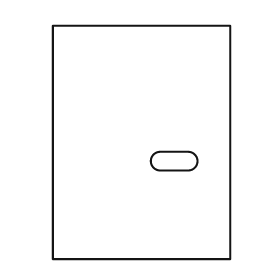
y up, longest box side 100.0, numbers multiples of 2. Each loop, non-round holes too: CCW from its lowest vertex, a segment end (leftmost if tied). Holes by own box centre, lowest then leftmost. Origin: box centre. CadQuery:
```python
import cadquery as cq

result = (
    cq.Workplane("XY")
    .moveTo(-38.0, -50.0)
    .lineTo(38.0, -50.0)
    .lineTo(38.0, 50.0)
    .lineTo(-38.0, 50.0)
    .close()
    .moveTo(8.0, -12.0)
    .lineTo(20.0, -12.0)
    .threePointArc((24.0, -8.0), (20.0, -4.0))
    .lineTo(8.0, -4.0)
    .threePointArc((4.0, -8.0), (8.0, -12.0))
    .close()
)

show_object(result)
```